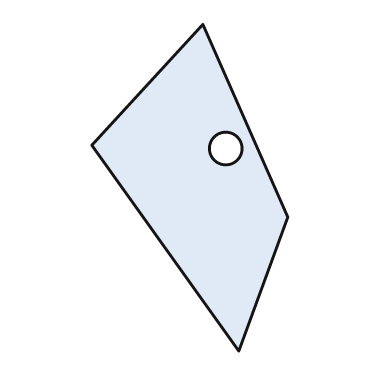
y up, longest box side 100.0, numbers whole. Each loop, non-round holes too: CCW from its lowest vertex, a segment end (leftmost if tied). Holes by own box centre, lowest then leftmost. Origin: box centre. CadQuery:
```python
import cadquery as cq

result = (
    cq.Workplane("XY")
    .moveTo(15.0, -50.0)
    .lineTo(30.0, -9.0)
    .lineTo(4.0, 50.0)
    .lineTo(-30.0, 13.0)
    .close()
    .moveTo(11.0, 12.0)
    .circle(5.0)
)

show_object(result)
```